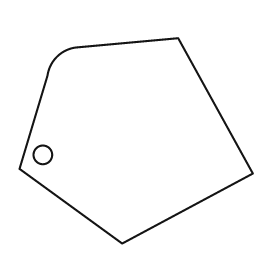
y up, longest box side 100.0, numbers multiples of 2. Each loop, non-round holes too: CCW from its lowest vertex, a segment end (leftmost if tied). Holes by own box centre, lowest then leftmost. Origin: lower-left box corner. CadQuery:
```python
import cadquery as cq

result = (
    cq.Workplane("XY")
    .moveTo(44.0, 0.0)
    .lineTo(100.0, 30.0)
    .lineTo(68.0, 88.0)
    .lineTo(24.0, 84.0)
    .threePointArc((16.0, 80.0), (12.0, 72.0))
    .lineTo(0.0, 32.0)
    .close()
    .moveTo(10.0, 38.0)
    .circle(4.0)
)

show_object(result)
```